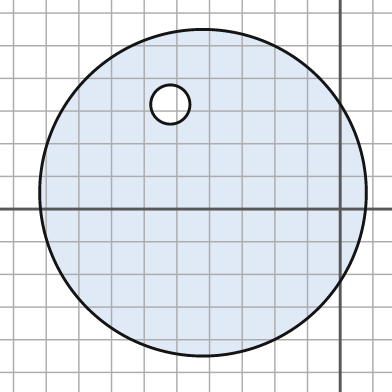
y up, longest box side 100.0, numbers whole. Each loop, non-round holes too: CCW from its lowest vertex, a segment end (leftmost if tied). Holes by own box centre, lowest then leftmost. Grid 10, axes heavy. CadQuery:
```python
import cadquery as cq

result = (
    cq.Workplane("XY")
    .moveTo(-42.0, 5.0)
    .circle(50.0)
    .moveTo(-52.0, 32.0)
    .circle(6.0)
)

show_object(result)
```